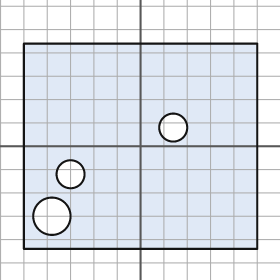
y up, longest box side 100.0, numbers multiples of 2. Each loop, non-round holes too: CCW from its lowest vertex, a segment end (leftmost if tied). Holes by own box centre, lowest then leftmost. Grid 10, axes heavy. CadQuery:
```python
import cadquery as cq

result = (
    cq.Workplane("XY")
    .moveTo(-50.0, -44.0)
    .lineTo(50.0, -44.0)
    .lineTo(50.0, 44.0)
    .lineTo(-50.0, 44.0)
    .close()
    .moveTo(-38.0, -30.0)
    .circle(8.0)
    .moveTo(-30.0, -12.0)
    .circle(6.0)
    .moveTo(14.0, 8.0)
    .circle(6.0)
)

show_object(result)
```